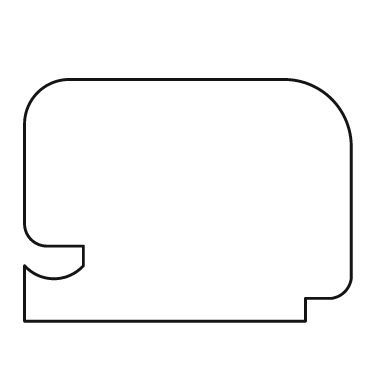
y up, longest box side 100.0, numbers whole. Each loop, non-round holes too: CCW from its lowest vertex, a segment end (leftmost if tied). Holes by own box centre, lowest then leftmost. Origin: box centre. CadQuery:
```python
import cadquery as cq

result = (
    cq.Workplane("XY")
    .moveTo(-50.0, -37.0)
    .lineTo(36.0, -37.0)
    .lineTo(36.0, -30.0)
    .lineTo(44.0, -30.0)
    .threePointArc((48.0, -28.0), (50.0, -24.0))
    .lineTo(50.0, 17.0)
    .threePointArc((44.0, 31.0), (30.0, 37.0))
    .lineTo(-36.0, 37.0)
    .threePointArc((-46.0, 33.0), (-50.0, 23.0))
    .lineTo(-50.0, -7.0)
    .threePointArc((-48.0, -12.0), (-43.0, -14.0))
    .lineTo(-32.0, -14.0)
    .lineTo(-32.0, -20.0)
    .threePointArc((-41.0, -24.0), (-50.0, -20.0))
    .close()
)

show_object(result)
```